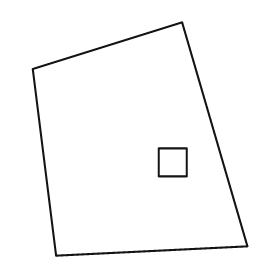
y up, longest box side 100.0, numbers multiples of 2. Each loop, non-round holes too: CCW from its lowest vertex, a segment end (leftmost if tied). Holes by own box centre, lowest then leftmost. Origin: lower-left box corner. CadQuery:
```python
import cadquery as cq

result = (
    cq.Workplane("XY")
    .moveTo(10.0, 0.0)
    .lineTo(92.0, 4.0)
    .lineTo(64.0, 100.0)
    .lineTo(0.0, 80.0)
    .close()
    .moveTo(54.0, 34.0)
    .lineTo(66.0, 34.0)
    .lineTo(66.0, 46.0)
    .lineTo(54.0, 46.0)
    .close()
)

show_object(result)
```